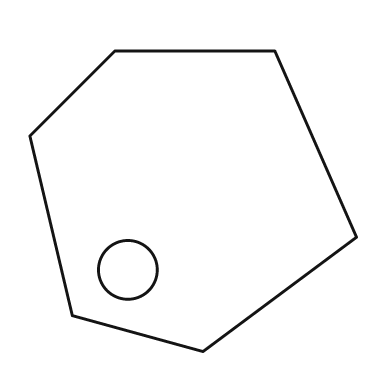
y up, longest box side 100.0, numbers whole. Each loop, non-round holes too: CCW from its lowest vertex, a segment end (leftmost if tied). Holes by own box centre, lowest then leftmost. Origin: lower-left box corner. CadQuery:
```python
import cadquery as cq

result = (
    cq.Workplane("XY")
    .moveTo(53.0, 0.0)
    .lineTo(100.0, 35.0)
    .lineTo(75.0, 92.0)
    .lineTo(26.0, 92.0)
    .lineTo(0.0, 66.0)
    .lineTo(13.0, 11.0)
    .close()
    .moveTo(30.0, 25.0)
    .circle(9.0)
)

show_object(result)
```